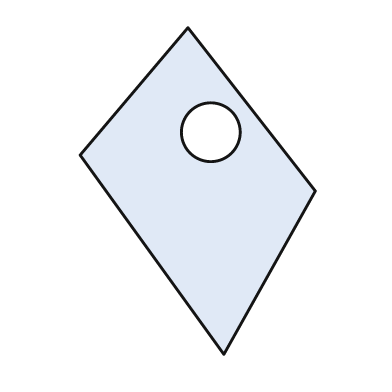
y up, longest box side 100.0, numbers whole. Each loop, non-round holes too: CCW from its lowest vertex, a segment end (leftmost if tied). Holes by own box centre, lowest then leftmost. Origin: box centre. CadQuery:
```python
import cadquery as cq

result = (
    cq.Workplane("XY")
    .moveTo(8.0, -50.0)
    .lineTo(36.0, 0.0)
    .lineTo(-3.0, 50.0)
    .lineTo(-36.0, 11.0)
    .close()
    .moveTo(4.0, 18.0)
    .circle(9.0)
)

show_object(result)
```